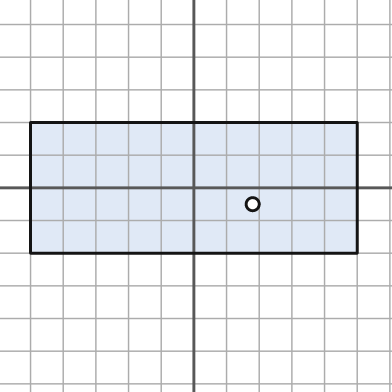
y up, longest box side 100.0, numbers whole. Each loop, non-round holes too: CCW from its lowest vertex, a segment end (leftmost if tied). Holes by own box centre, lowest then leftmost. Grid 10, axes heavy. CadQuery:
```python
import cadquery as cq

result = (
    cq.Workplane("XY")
    .moveTo(-50.0, -20.0)
    .lineTo(50.0, -20.0)
    .lineTo(50.0, 20.0)
    .lineTo(-50.0, 20.0)
    .close()
    .moveTo(18.0, -5.0)
    .circle(2.0)
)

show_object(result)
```